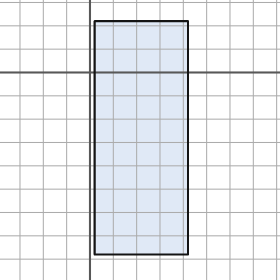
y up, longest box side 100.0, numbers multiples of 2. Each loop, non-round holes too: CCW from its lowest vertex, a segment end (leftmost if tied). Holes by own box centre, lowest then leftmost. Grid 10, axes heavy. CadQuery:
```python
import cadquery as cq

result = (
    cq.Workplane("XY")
    .moveTo(2.0, -78.0)
    .lineTo(42.0, -78.0)
    .lineTo(42.0, 22.0)
    .lineTo(2.0, 22.0)
    .close()
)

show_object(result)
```